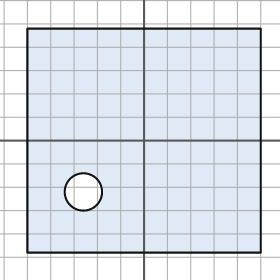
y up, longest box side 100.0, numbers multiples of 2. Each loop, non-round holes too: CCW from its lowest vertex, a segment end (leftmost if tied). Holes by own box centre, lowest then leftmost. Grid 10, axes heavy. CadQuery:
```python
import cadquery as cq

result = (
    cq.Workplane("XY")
    .moveTo(-50.0, -48.0)
    .lineTo(50.0, -48.0)
    .lineTo(50.0, 48.0)
    .lineTo(-50.0, 48.0)
    .close()
    .moveTo(-26.0, -22.0)
    .circle(8.0)
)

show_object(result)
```